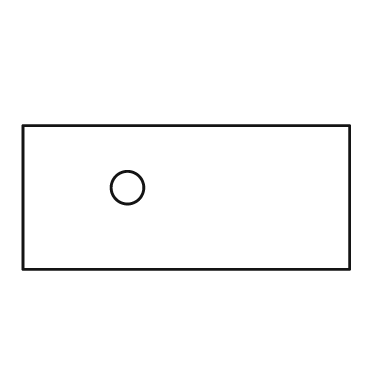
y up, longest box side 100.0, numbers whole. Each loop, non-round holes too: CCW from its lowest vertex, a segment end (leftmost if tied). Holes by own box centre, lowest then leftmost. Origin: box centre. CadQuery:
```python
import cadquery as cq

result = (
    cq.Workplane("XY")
    .moveTo(-50.0, -22.0)
    .lineTo(50.0, -22.0)
    .lineTo(50.0, 22.0)
    .lineTo(-50.0, 22.0)
    .close()
    .moveTo(-18.0, 3.0)
    .circle(5.0)
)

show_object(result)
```